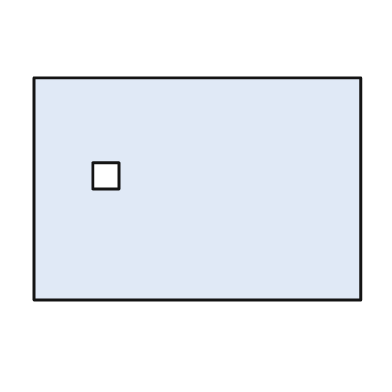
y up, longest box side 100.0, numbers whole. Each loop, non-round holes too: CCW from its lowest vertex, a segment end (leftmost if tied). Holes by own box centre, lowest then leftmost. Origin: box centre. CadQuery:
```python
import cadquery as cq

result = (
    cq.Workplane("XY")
    .moveTo(-50.0, -34.0)
    .lineTo(50.0, -34.0)
    .lineTo(50.0, 34.0)
    .lineTo(-50.0, 34.0)
    .close()
    .moveTo(-32.0, 0.0)
    .lineTo(-24.0, 0.0)
    .lineTo(-24.0, 8.0)
    .lineTo(-32.0, 8.0)
    .close()
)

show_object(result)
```